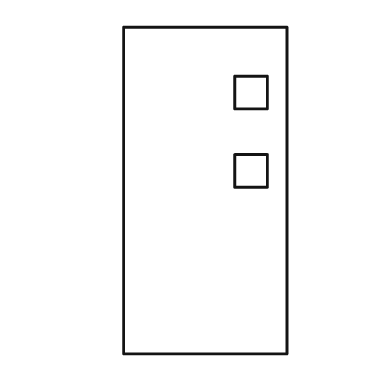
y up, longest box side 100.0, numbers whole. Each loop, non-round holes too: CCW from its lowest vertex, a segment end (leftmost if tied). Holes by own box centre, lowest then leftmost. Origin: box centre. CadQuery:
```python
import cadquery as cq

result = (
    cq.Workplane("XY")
    .moveTo(-25.0, -50.0)
    .lineTo(25.0, -50.0)
    .lineTo(25.0, 50.0)
    .lineTo(-25.0, 50.0)
    .close()
    .moveTo(9.0, 1.0)
    .lineTo(19.0, 1.0)
    .lineTo(19.0, 11.0)
    .lineTo(9.0, 11.0)
    .close()
    .moveTo(9.0, 25.0)
    .lineTo(19.0, 25.0)
    .lineTo(19.0, 35.0)
    .lineTo(9.0, 35.0)
    .close()
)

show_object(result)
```